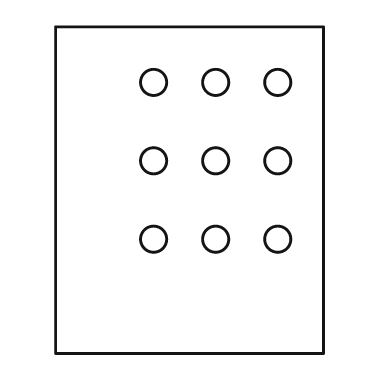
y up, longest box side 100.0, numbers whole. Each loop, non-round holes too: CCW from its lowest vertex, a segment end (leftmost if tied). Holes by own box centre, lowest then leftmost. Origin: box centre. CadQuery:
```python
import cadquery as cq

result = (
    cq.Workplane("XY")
    .moveTo(-41.0, -50.0)
    .lineTo(41.0, -50.0)
    .lineTo(41.0, 50.0)
    .lineTo(-41.0, 50.0)
    .close()
    .moveTo(-11.0, -15.0)
    .circle(4.0)
    .moveTo(8.0, -15.0)
    .circle(4.0)
    .moveTo(27.0, -15.0)
    .circle(4.0)
    .moveTo(-11.0, 9.0)
    .circle(4.0)
    .moveTo(8.0, 9.0)
    .circle(4.0)
    .moveTo(27.0, 9.0)
    .circle(4.0)
    .moveTo(-11.0, 33.0)
    .circle(4.0)
    .moveTo(8.0, 33.0)
    .circle(4.0)
    .moveTo(27.0, 33.0)
    .circle(4.0)
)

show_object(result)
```